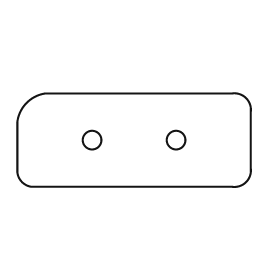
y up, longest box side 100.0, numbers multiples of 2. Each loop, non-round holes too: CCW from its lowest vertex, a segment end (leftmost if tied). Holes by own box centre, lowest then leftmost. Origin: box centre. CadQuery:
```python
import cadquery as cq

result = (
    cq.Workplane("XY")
    .moveTo(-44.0, -20.0)
    .lineTo(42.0, -20.0)
    .threePointArc((48.0, -18.0), (50.0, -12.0))
    .lineTo(50.0, 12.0)
    .threePointArc((48.0, 18.0), (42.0, 20.0))
    .lineTo(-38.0, 20.0)
    .threePointArc((-46.0, 16.0), (-50.0, 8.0))
    .lineTo(-50.0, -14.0)
    .threePointArc((-48.0, -18.0), (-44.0, -20.0))
    .close()
    .moveTo(-18.0, 0.0)
    .circle(4.0)
    .moveTo(18.0, 0.0)
    .circle(4.0)
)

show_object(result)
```